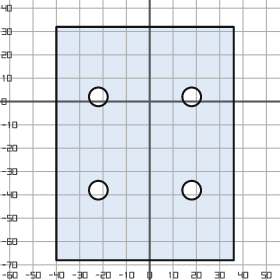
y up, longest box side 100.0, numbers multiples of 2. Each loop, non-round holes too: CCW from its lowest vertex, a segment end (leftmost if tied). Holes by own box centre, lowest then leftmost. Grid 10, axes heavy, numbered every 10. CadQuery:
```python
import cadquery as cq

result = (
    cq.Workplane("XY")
    .moveTo(-40.0, -68.0)
    .lineTo(36.0, -68.0)
    .lineTo(36.0, 32.0)
    .lineTo(-40.0, 32.0)
    .close()
    .moveTo(-22.0, -38.0)
    .circle(4.0)
    .moveTo(18.0, -38.0)
    .circle(4.0)
    .moveTo(-22.0, 2.0)
    .circle(4.0)
    .moveTo(18.0, 2.0)
    .circle(4.0)
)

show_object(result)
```